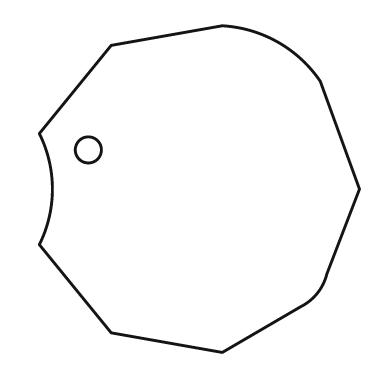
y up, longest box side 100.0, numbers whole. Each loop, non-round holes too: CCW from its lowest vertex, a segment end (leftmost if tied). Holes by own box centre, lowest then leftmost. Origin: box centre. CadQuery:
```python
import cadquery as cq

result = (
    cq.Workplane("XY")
    .moveTo(7.0, -50.0)
    .lineTo(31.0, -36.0)
    .threePointArc((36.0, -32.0), (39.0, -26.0))
    .lineTo(49.0, 0.0)
    .lineTo(37.0, 33.0)
    .threePointArc((24.0, 45.0), (7.0, 50.0))
    .lineTo(-27.0, 44.0)
    .lineTo(-49.0, 17.0)
    .threePointArc((-45.0, 0.0), (-49.0, -17.0))
    .lineTo(-27.0, -44.0)
    .close()
    .moveTo(-34.0, 12.0)
    .circle(4.0)
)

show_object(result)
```